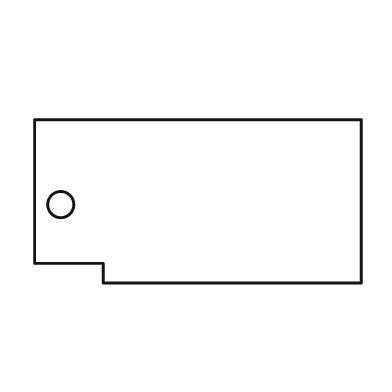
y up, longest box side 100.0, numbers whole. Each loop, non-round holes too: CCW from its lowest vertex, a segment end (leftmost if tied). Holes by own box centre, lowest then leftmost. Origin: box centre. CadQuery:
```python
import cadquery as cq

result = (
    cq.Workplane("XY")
    .moveTo(-29.0, -25.0)
    .lineTo(50.0, -25.0)
    .lineTo(50.0, 25.0)
    .lineTo(-50.0, 25.0)
    .lineTo(-50.0, -19.0)
    .lineTo(-29.0, -19.0)
    .close()
    .moveTo(-42.0, -1.0)
    .circle(4.0)
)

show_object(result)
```